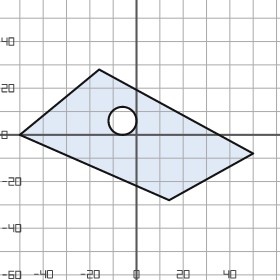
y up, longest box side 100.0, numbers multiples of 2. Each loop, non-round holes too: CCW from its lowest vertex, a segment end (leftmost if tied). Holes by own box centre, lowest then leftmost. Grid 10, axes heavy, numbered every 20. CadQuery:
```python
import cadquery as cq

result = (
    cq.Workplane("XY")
    .moveTo(14.0, -28.0)
    .lineTo(50.0, -8.0)
    .lineTo(-16.0, 28.0)
    .lineTo(-50.0, 0.0)
    .close()
    .moveTo(-6.0, 6.0)
    .circle(6.0)
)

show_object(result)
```